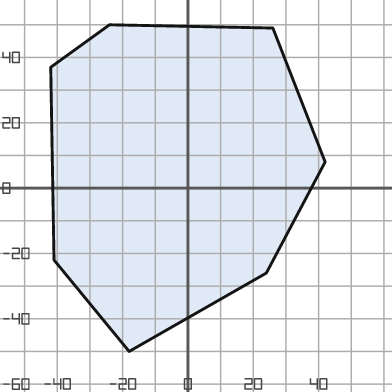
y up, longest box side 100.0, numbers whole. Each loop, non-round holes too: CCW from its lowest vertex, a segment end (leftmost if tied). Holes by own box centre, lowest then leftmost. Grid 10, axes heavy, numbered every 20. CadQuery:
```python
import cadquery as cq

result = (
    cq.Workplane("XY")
    .moveTo(-18.0, -50.0)
    .lineTo(24.0, -26.0)
    .lineTo(42.0, 8.0)
    .lineTo(26.0, 49.0)
    .lineTo(-24.0, 50.0)
    .lineTo(-42.0, 37.0)
    .lineTo(-41.0, -22.0)
    .close()
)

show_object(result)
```